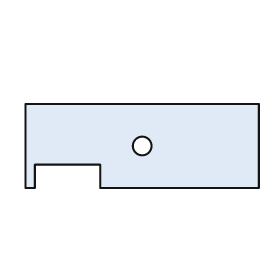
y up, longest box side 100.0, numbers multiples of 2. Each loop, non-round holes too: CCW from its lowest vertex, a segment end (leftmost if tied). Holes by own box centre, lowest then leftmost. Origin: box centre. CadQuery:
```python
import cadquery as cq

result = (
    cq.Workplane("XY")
    .moveTo(-50.0, -18.0)
    .lineTo(-46.0, -18.0)
    .lineTo(-46.0, -8.0)
    .lineTo(-18.0, -8.0)
    .lineTo(-18.0, -18.0)
    .lineTo(50.0, -18.0)
    .lineTo(50.0, 18.0)
    .lineTo(-50.0, 18.0)
    .close()
    .moveTo(0.0, 0.0)
    .circle(4.0)
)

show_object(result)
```